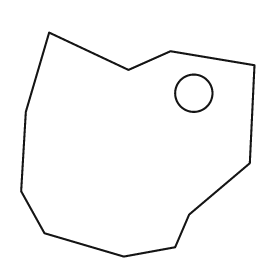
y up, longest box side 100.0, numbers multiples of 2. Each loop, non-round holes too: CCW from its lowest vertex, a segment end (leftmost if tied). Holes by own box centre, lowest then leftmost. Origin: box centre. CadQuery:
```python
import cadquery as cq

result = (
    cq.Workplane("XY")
    .moveTo(-6.0, -48.0)
    .lineTo(16.0, -44.0)
    .lineTo(22.0, -30.0)
    .lineTo(48.0, -8.0)
    .lineTo(50.0, 34.0)
    .lineTo(14.0, 40.0)
    .lineTo(-4.0, 32.0)
    .lineTo(-38.0, 48.0)
    .lineTo(-48.0, 14.0)
    .lineTo(-50.0, -20.0)
    .lineTo(-40.0, -38.0)
    .close()
    .moveTo(24.0, 22.0)
    .circle(8.0)
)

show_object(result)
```